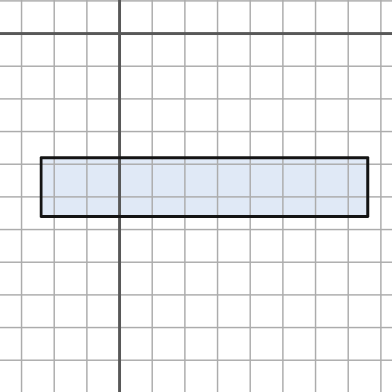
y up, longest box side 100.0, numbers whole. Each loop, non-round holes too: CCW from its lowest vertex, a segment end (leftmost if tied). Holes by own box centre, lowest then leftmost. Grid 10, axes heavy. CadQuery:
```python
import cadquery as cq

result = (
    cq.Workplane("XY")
    .moveTo(-24.0, -56.0)
    .lineTo(76.0, -56.0)
    .lineTo(76.0, -38.0)
    .lineTo(-24.0, -38.0)
    .close()
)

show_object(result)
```